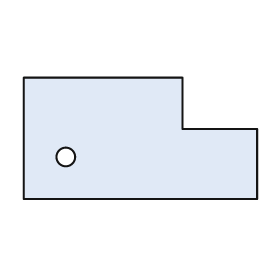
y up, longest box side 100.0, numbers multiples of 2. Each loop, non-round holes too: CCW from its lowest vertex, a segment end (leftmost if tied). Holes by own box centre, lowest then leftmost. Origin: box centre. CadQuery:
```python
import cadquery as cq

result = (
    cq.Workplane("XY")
    .moveTo(-50.0, -26.0)
    .lineTo(50.0, -26.0)
    .lineTo(50.0, 4.0)
    .lineTo(18.0, 4.0)
    .lineTo(18.0, 26.0)
    .lineTo(-50.0, 26.0)
    .close()
    .moveTo(-32.0, -8.0)
    .circle(4.0)
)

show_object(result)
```